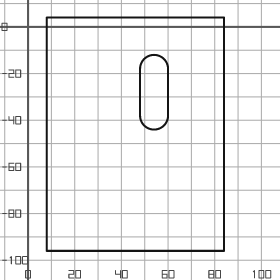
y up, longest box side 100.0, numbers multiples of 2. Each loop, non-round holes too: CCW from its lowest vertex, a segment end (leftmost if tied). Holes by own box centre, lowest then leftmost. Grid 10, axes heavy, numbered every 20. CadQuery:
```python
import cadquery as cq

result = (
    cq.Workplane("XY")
    .moveTo(8.0, -96.0)
    .lineTo(84.0, -96.0)
    .lineTo(84.0, 4.0)
    .lineTo(8.0, 4.0)
    .close()
    .moveTo(48.0, -38.0)
    .threePointArc((54.0, -44.0), (60.0, -38.0))
    .lineTo(60.0, -18.0)
    .threePointArc((54.0, -12.0), (48.0, -18.0))
    .close()
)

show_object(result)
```